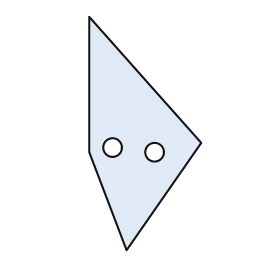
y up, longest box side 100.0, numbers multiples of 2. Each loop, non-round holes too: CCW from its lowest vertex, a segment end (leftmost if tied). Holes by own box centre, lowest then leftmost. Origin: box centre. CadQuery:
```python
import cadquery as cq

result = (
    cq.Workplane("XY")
    .moveTo(-8.0, -50.0)
    .lineTo(24.0, -4.0)
    .lineTo(-24.0, 50.0)
    .lineTo(-24.0, -8.0)
    .close()
    .moveTo(4.0, -8.0)
    .circle(4.0)
    .moveTo(-14.0, -6.0)
    .circle(4.0)
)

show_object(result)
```